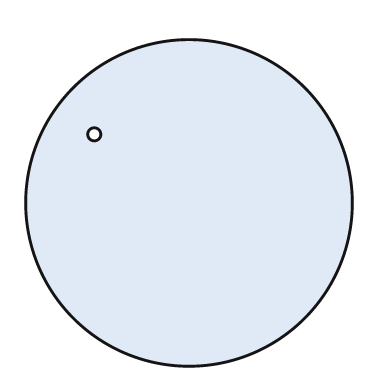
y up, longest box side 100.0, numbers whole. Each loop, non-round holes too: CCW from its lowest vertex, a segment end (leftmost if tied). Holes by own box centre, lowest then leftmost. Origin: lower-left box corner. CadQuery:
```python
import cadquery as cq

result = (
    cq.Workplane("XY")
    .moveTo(50.0, 50.0)
    .circle(50.0)
    .moveTo(21.0, 71.0)
    .circle(2.0)
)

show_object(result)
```